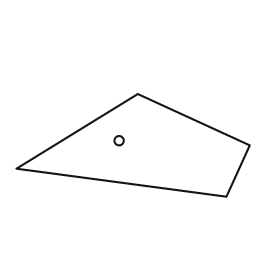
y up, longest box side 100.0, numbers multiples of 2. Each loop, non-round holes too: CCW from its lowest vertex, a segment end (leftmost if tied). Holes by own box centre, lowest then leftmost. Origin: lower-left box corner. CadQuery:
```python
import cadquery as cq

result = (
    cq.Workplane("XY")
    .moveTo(90.0, 0.0)
    .lineTo(100.0, 22.0)
    .lineTo(52.0, 44.0)
    .lineTo(0.0, 12.0)
    .close()
    .moveTo(44.0, 24.0)
    .circle(2.0)
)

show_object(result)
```